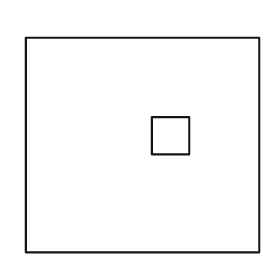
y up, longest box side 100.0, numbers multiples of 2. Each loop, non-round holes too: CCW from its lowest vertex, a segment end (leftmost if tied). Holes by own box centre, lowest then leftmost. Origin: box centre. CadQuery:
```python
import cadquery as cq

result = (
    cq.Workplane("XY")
    .moveTo(-50.0, -46.0)
    .lineTo(50.0, -46.0)
    .lineTo(50.0, 46.0)
    .lineTo(-50.0, 46.0)
    .close()
    .moveTo(4.0, -4.0)
    .lineTo(20.0, -4.0)
    .lineTo(20.0, 12.0)
    .lineTo(4.0, 12.0)
    .close()
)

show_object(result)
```